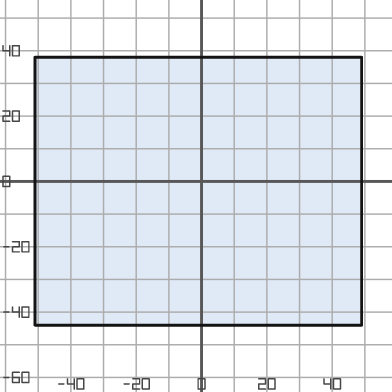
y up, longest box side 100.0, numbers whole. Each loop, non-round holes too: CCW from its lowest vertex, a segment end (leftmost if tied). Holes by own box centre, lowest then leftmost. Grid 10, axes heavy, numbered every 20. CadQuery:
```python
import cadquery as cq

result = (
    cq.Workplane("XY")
    .moveTo(-51.0, -44.0)
    .lineTo(49.0, -44.0)
    .lineTo(49.0, 38.0)
    .lineTo(-51.0, 38.0)
    .close()
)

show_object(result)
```